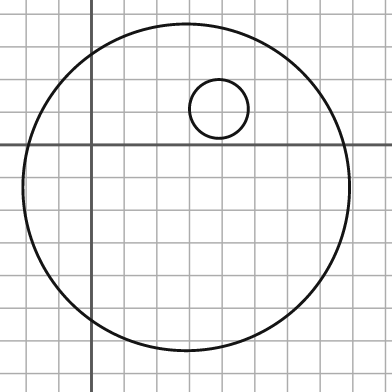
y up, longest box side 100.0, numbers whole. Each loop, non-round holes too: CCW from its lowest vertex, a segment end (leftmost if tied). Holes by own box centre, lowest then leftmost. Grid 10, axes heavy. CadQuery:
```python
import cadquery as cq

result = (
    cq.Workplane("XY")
    .moveTo(29.0, -13.0)
    .circle(50.0)
    .moveTo(39.0, 11.0)
    .circle(9.0)
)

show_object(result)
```